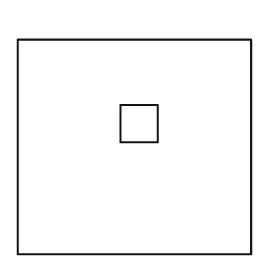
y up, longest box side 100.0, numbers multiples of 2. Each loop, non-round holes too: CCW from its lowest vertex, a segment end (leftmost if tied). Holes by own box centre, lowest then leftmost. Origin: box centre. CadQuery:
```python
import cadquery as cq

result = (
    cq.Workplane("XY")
    .moveTo(-50.0, -46.0)
    .lineTo(50.0, -46.0)
    .lineTo(50.0, 46.0)
    .lineTo(-50.0, 46.0)
    .close()
    .moveTo(-6.0, 2.0)
    .lineTo(10.0, 2.0)
    .lineTo(10.0, 18.0)
    .lineTo(-6.0, 18.0)
    .close()
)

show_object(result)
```